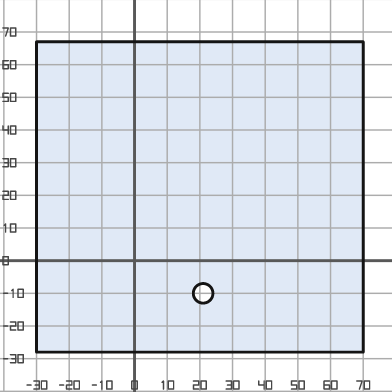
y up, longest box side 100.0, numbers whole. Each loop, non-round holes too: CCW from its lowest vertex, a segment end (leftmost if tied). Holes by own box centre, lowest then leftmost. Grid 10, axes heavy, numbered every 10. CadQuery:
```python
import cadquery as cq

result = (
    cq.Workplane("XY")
    .moveTo(-30.0, -28.0)
    .lineTo(70.0, -28.0)
    .lineTo(70.0, 67.0)
    .lineTo(-30.0, 67.0)
    .close()
    .moveTo(21.0, -10.0)
    .circle(3.0)
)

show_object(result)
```